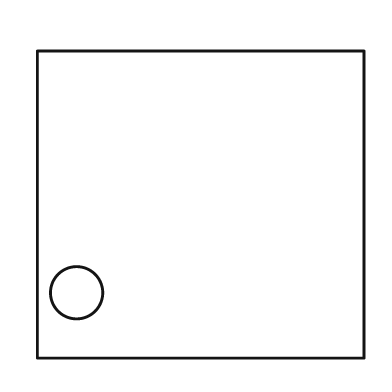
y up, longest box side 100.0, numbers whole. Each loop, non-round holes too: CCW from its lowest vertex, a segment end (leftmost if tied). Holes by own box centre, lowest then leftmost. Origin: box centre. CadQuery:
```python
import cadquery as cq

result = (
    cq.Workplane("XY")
    .moveTo(-50.0, -47.0)
    .lineTo(50.0, -47.0)
    .lineTo(50.0, 47.0)
    .lineTo(-50.0, 47.0)
    .close()
    .moveTo(-38.0, -27.0)
    .circle(8.0)
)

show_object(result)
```